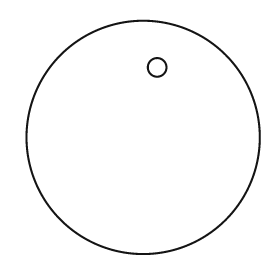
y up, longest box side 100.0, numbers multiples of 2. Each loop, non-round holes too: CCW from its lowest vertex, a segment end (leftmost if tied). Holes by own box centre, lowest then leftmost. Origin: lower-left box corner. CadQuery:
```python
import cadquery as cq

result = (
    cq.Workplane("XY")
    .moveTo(50.0, 50.0)
    .circle(50.0)
    .moveTo(56.0, 80.0)
    .circle(4.0)
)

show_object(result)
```